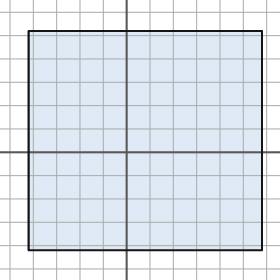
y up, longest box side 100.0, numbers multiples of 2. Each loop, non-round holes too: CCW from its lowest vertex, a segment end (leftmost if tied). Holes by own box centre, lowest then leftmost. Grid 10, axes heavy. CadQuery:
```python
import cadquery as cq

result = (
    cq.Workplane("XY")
    .moveTo(-42.0, -42.0)
    .lineTo(58.0, -42.0)
    .lineTo(58.0, 52.0)
    .lineTo(-42.0, 52.0)
    .close()
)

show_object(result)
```